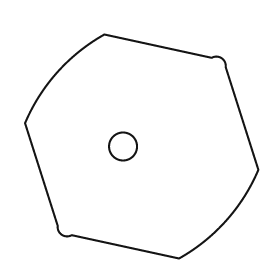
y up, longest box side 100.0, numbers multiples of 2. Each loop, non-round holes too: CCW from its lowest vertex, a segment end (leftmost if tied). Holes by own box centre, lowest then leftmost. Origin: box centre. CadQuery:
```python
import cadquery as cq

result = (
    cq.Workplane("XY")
    .moveTo(16.0, -48.0)
    .threePointArc((36.0, -32.0), (50.0, -10.0))
    .lineTo(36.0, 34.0)
    .threePointArc((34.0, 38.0), (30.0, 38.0))
    .lineTo(-16.0, 48.0)
    .threePointArc((-36.0, 32.0), (-50.0, 10.0))
    .lineTo(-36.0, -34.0)
    .threePointArc((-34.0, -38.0), (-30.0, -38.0))
    .close()
    .moveTo(-8.0, 0.0)
    .circle(6.0)
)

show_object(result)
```